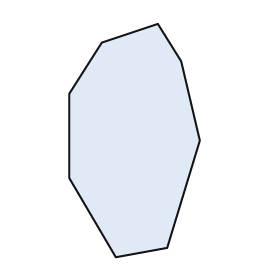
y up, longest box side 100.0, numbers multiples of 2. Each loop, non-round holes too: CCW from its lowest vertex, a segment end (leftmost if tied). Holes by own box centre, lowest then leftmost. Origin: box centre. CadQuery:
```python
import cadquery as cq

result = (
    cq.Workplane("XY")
    .moveTo(-8.0, -50.0)
    .lineTo(14.0, -46.0)
    .lineTo(28.0, 0.0)
    .lineTo(20.0, 34.0)
    .lineTo(10.0, 50.0)
    .lineTo(-14.0, 42.0)
    .lineTo(-28.0, 20.0)
    .lineTo(-28.0, -16.0)
    .close()
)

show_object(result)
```